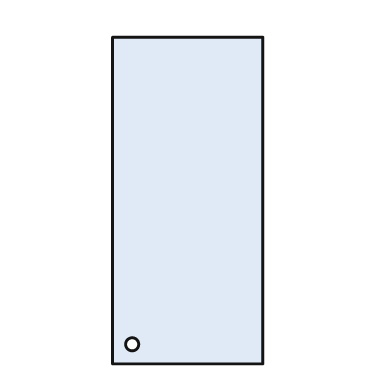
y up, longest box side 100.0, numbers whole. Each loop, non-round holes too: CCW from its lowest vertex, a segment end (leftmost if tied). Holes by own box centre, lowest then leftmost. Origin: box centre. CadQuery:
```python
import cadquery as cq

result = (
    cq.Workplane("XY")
    .moveTo(-23.0, -50.0)
    .lineTo(23.0, -50.0)
    .lineTo(23.0, 50.0)
    .lineTo(-23.0, 50.0)
    .close()
    .moveTo(-17.0, -44.0)
    .circle(2.0)
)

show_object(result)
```